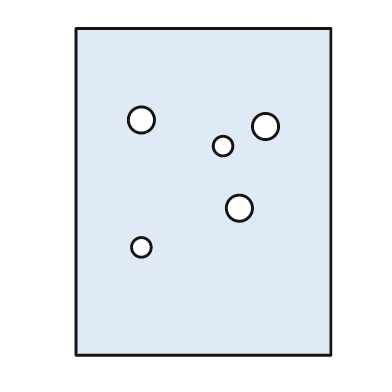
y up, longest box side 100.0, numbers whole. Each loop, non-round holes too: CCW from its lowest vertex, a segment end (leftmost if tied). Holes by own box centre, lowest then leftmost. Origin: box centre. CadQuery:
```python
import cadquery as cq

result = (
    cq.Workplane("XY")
    .moveTo(-39.0, -50.0)
    .lineTo(39.0, -50.0)
    .lineTo(39.0, 50.0)
    .lineTo(-39.0, 50.0)
    .close()
    .moveTo(-19.0, -17.0)
    .circle(3.0)
    .moveTo(11.0, -5.0)
    .circle(4.0)
    .moveTo(6.0, 14.0)
    .circle(3.0)
    .moveTo(19.0, 20.0)
    .circle(4.0)
    .moveTo(-19.0, 22.0)
    .circle(4.0)
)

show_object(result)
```